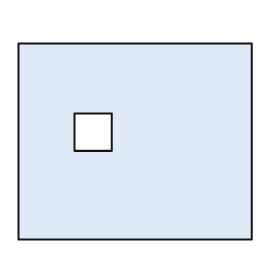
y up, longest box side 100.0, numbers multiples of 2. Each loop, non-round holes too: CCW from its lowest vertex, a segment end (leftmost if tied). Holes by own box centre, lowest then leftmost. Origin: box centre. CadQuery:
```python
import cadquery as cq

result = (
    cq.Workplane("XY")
    .moveTo(-50.0, -42.0)
    .lineTo(50.0, -42.0)
    .lineTo(50.0, 42.0)
    .lineTo(-50.0, 42.0)
    .close()
    .moveTo(-26.0, -4.0)
    .lineTo(-10.0, -4.0)
    .lineTo(-10.0, 12.0)
    .lineTo(-26.0, 12.0)
    .close()
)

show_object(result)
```